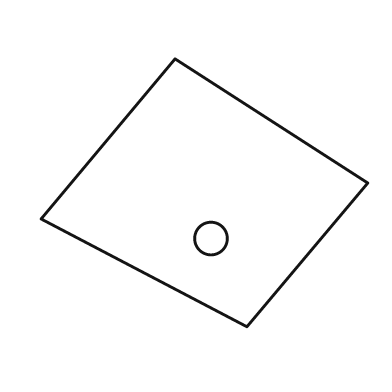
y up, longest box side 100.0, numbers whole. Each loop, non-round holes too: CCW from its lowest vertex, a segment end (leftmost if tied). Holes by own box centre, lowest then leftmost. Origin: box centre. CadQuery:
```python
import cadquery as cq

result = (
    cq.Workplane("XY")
    .moveTo(13.0, -41.0)
    .lineTo(50.0, 3.0)
    .lineTo(-9.0, 41.0)
    .lineTo(-50.0, -8.0)
    .close()
    .moveTo(2.0, -14.0)
    .circle(5.0)
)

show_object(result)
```